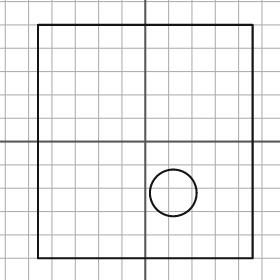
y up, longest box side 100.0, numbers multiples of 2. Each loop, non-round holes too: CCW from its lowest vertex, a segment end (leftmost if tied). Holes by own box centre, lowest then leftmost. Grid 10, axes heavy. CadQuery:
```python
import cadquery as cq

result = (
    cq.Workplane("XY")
    .moveTo(-46.0, -50.0)
    .lineTo(46.0, -50.0)
    .lineTo(46.0, 50.0)
    .lineTo(-46.0, 50.0)
    .close()
    .moveTo(12.0, -22.0)
    .circle(10.0)
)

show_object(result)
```